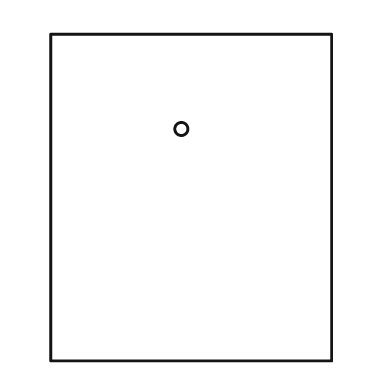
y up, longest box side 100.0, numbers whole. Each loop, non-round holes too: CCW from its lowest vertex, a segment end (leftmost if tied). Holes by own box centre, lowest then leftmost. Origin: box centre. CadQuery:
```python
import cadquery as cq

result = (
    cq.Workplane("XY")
    .moveTo(-43.0, -50.0)
    .lineTo(43.0, -50.0)
    .lineTo(43.0, 50.0)
    .lineTo(-43.0, 50.0)
    .close()
    .moveTo(-3.0, 21.0)
    .circle(2.0)
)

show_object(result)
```